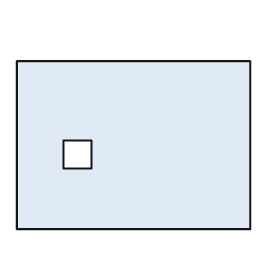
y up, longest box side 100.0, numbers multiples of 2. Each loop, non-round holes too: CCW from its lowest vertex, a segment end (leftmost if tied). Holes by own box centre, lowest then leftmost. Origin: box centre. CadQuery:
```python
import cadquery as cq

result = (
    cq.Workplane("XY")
    .moveTo(-50.0, -36.0)
    .lineTo(50.0, -36.0)
    .lineTo(50.0, 36.0)
    .lineTo(-50.0, 36.0)
    .close()
    .moveTo(-30.0, -10.0)
    .lineTo(-18.0, -10.0)
    .lineTo(-18.0, 2.0)
    .lineTo(-30.0, 2.0)
    .close()
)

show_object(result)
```